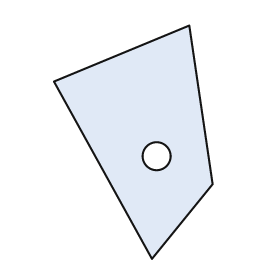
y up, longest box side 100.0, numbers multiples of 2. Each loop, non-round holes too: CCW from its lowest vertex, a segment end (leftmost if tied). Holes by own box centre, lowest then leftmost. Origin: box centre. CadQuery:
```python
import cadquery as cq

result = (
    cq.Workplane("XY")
    .moveTo(8.0, -50.0)
    .lineTo(34.0, -18.0)
    .lineTo(24.0, 50.0)
    .lineTo(-34.0, 26.0)
    .close()
    .moveTo(10.0, -6.0)
    .circle(6.0)
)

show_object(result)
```